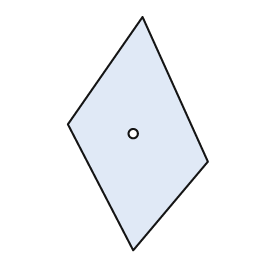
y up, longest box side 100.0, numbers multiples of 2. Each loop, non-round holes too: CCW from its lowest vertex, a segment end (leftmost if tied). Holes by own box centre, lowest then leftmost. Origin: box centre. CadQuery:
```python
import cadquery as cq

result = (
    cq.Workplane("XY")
    .moveTo(-2.0, -50.0)
    .lineTo(30.0, -12.0)
    .lineTo(2.0, 50.0)
    .lineTo(-30.0, 4.0)
    .close()
    .moveTo(-2.0, 0.0)
    .circle(2.0)
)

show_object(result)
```